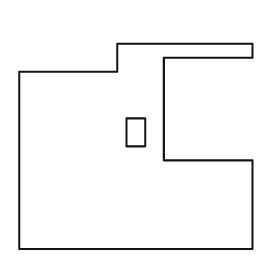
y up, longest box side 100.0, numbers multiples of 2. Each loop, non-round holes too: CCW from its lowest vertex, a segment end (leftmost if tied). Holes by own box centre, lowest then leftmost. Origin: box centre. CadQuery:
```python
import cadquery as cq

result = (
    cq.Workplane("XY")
    .moveTo(-50.0, -44.0)
    .lineTo(50.0, -44.0)
    .lineTo(50.0, -6.0)
    .lineTo(12.0, -6.0)
    .lineTo(12.0, 38.0)
    .lineTo(50.0, 38.0)
    .lineTo(50.0, 44.0)
    .lineTo(-8.0, 44.0)
    .lineTo(-8.0, 32.0)
    .lineTo(-50.0, 32.0)
    .close()
    .moveTo(-4.0, 0.0)
    .lineTo(4.0, 0.0)
    .lineTo(4.0, 12.0)
    .lineTo(-4.0, 12.0)
    .close()
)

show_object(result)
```